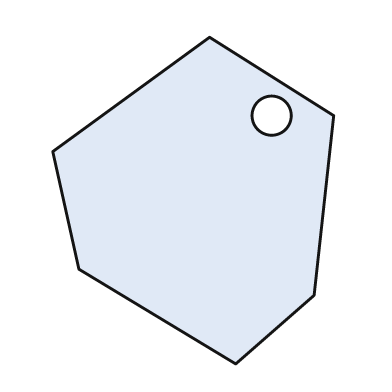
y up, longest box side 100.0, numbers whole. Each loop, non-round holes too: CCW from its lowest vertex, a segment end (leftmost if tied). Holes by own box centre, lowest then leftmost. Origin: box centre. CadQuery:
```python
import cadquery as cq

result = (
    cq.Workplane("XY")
    .moveTo(13.0, -50.0)
    .lineTo(37.0, -29.0)
    .lineTo(43.0, 26.0)
    .lineTo(5.0, 50.0)
    .lineTo(-43.0, 15.0)
    .lineTo(-35.0, -21.0)
    .close()
    .moveTo(24.0, 26.0)
    .circle(6.0)
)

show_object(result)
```